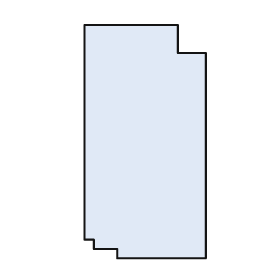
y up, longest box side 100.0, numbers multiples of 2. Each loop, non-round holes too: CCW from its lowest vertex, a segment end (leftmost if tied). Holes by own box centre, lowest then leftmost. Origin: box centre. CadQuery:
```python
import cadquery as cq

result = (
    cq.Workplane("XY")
    .moveTo(-12.0, -50.0)
    .lineTo(26.0, -50.0)
    .lineTo(26.0, 38.0)
    .lineTo(14.0, 38.0)
    .lineTo(14.0, 50.0)
    .lineTo(-26.0, 50.0)
    .lineTo(-26.0, -42.0)
    .lineTo(-22.0, -42.0)
    .lineTo(-22.0, -46.0)
    .lineTo(-12.0, -46.0)
    .close()
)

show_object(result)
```